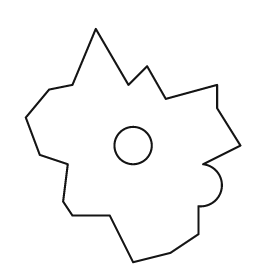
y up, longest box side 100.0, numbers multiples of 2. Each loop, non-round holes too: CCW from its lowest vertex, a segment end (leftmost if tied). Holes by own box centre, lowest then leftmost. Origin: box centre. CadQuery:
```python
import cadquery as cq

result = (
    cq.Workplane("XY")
    .moveTo(0.0, -50.0)
    .lineTo(16.0, -46.0)
    .lineTo(28.0, -38.0)
    .lineTo(28.0, -26.0)
    .threePointArc((38.0, -18.0), (30.0, -8.0))
    .lineTo(46.0, 0.0)
    .lineTo(36.0, 16.0)
    .lineTo(36.0, 26.0)
    .lineTo(14.0, 20.0)
    .lineTo(6.0, 34.0)
    .lineTo(-2.0, 26.0)
    .lineTo(-16.0, 50.0)
    .lineTo(-26.0, 26.0)
    .lineTo(-36.0, 24.0)
    .lineTo(-46.0, 12.0)
    .lineTo(-40.0, -4.0)
    .lineTo(-28.0, -8.0)
    .lineTo(-30.0, -24.0)
    .lineTo(-26.0, -30.0)
    .lineTo(-10.0, -30.0)
    .close()
    .moveTo(0.0, 0.0)
    .circle(8.0)
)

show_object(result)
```